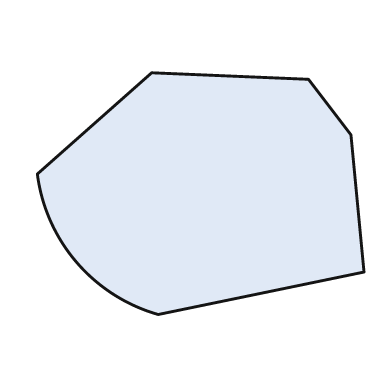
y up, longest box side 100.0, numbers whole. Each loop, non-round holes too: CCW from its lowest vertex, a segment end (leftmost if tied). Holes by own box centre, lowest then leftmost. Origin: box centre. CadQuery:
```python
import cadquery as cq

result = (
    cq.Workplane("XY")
    .moveTo(-13.0, -37.0)
    .lineTo(50.0, -24.0)
    .lineTo(46.0, 18.0)
    .lineTo(33.0, 35.0)
    .lineTo(-15.0, 37.0)
    .lineTo(-50.0, 6.0)
    .threePointArc((-38.0, -21.0), (-13.0, -37.0))
    .close()
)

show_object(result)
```